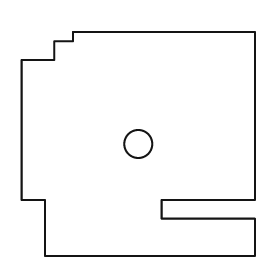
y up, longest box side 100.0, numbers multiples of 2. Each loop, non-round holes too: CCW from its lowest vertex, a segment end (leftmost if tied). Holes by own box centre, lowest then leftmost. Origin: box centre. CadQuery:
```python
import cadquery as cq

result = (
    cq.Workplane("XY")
    .moveTo(-40.0, -48.0)
    .lineTo(50.0, -48.0)
    .lineTo(50.0, -32.0)
    .lineTo(10.0, -32.0)
    .lineTo(10.0, -24.0)
    .lineTo(50.0, -24.0)
    .lineTo(50.0, 48.0)
    .lineTo(-28.0, 48.0)
    .lineTo(-28.0, 44.0)
    .lineTo(-36.0, 44.0)
    .lineTo(-36.0, 36.0)
    .lineTo(-50.0, 36.0)
    .lineTo(-50.0, -24.0)
    .lineTo(-40.0, -24.0)
    .close()
    .moveTo(0.0, 0.0)
    .circle(6.0)
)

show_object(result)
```